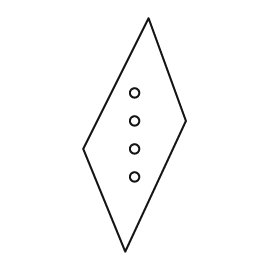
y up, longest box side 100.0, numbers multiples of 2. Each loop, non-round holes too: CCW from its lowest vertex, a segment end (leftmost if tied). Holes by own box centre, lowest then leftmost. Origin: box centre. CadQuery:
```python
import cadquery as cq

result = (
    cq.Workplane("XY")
    .moveTo(-4.0, -50.0)
    .lineTo(22.0, 6.0)
    .lineTo(6.0, 50.0)
    .lineTo(-22.0, -6.0)
    .close()
    .moveTo(0.0, -18.0)
    .circle(2.0)
    .moveTo(0.0, -6.0)
    .circle(2.0)
    .moveTo(0.0, 6.0)
    .circle(2.0)
    .moveTo(0.0, 18.0)
    .circle(2.0)
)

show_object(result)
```